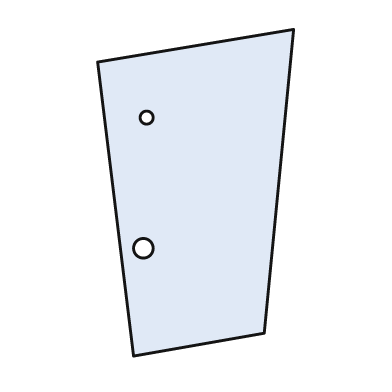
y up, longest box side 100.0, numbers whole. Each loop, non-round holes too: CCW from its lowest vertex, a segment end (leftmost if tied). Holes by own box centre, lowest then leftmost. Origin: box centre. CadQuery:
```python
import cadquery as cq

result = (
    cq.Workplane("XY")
    .moveTo(-19.0, -50.0)
    .lineTo(21.0, -43.0)
    .lineTo(30.0, 50.0)
    .lineTo(-30.0, 40.0)
    .close()
    .moveTo(-16.0, -17.0)
    .circle(3.0)
    .moveTo(-15.0, 23.0)
    .circle(2.0)
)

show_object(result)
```